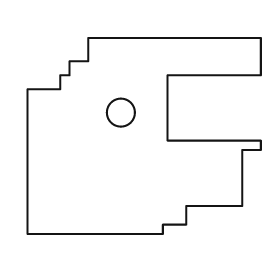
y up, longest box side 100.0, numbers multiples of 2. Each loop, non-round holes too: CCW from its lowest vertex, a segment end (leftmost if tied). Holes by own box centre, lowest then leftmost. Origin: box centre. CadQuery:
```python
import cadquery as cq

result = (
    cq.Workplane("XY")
    .moveTo(-50.0, -42.0)
    .lineTo(8.0, -42.0)
    .lineTo(8.0, -38.0)
    .lineTo(18.0, -38.0)
    .lineTo(18.0, -30.0)
    .lineTo(42.0, -30.0)
    .lineTo(42.0, -6.0)
    .lineTo(50.0, -6.0)
    .lineTo(50.0, -2.0)
    .lineTo(10.0, -2.0)
    .lineTo(10.0, 26.0)
    .lineTo(50.0, 26.0)
    .lineTo(50.0, 42.0)
    .lineTo(-24.0, 42.0)
    .lineTo(-24.0, 32.0)
    .lineTo(-32.0, 32.0)
    .lineTo(-32.0, 26.0)
    .lineTo(-36.0, 26.0)
    .lineTo(-36.0, 20.0)
    .lineTo(-50.0, 20.0)
    .close()
    .moveTo(-10.0, 10.0)
    .circle(6.0)
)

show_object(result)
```